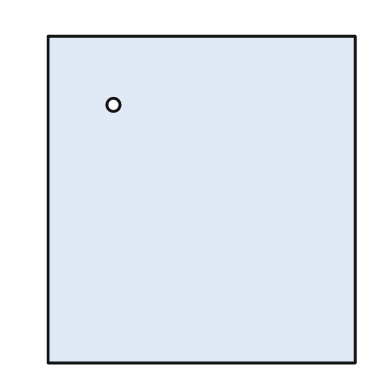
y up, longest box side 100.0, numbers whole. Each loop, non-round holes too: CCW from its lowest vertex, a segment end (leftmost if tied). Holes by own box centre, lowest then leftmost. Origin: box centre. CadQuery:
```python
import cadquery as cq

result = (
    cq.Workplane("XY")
    .moveTo(-47.0, -50.0)
    .lineTo(47.0, -50.0)
    .lineTo(47.0, 50.0)
    .lineTo(-47.0, 50.0)
    .close()
    .moveTo(-27.0, 29.0)
    .circle(2.0)
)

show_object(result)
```